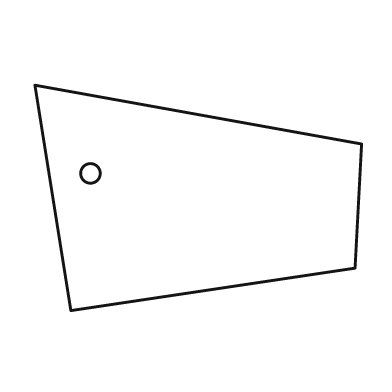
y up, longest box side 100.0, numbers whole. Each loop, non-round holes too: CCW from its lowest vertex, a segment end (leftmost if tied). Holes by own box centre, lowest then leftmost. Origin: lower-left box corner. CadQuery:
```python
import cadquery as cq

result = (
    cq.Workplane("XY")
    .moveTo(11.0, 0.0)
    .lineTo(98.0, 13.0)
    .lineTo(100.0, 51.0)
    .lineTo(0.0, 69.0)
    .close()
    .moveTo(17.0, 42.0)
    .circle(3.0)
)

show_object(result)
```